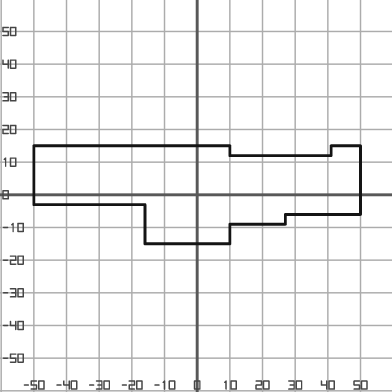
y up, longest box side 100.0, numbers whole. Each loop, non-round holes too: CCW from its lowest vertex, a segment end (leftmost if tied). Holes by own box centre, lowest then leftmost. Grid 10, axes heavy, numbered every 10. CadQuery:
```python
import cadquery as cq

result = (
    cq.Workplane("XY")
    .moveTo(-16.0, -15.0)
    .lineTo(10.0, -15.0)
    .lineTo(10.0, -9.0)
    .lineTo(27.0, -9.0)
    .lineTo(27.0, -6.0)
    .lineTo(50.0, -6.0)
    .lineTo(50.0, 15.0)
    .lineTo(41.0, 15.0)
    .lineTo(41.0, 12.0)
    .lineTo(10.0, 12.0)
    .lineTo(10.0, 15.0)
    .lineTo(-50.0, 15.0)
    .lineTo(-50.0, -3.0)
    .lineTo(-16.0, -3.0)
    .close()
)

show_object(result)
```